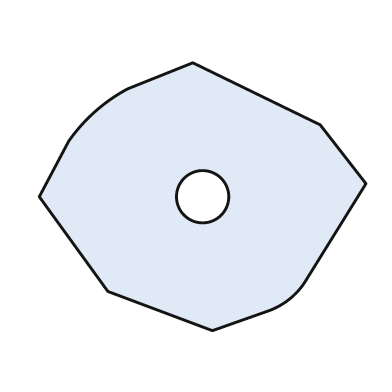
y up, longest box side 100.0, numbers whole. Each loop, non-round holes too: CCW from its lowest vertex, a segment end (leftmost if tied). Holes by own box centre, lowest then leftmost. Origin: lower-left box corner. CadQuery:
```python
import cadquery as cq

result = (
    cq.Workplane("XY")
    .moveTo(53.0, 0.0)
    .lineTo(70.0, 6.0)
    .threePointArc((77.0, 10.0), (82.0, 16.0))
    .lineTo(100.0, 45.0)
    .lineTo(86.0, 63.0)
    .lineTo(47.0, 82.0)
    .lineTo(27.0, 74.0)
    .threePointArc((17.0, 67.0), (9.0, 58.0))
    .lineTo(0.0, 41.0)
    .lineTo(21.0, 12.0)
    .close()
    .moveTo(50.0, 41.0)
    .circle(8.0)
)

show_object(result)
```